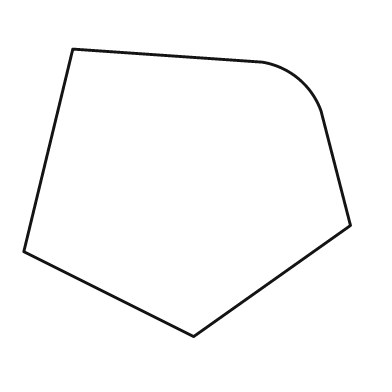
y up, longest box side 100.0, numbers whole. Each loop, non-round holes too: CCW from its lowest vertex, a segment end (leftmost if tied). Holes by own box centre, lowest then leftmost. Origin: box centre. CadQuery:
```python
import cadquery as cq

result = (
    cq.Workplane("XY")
    .moveTo(2.0, -44.0)
    .lineTo(50.0, -10.0)
    .lineTo(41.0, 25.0)
    .threePointArc((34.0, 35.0), (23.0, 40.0))
    .lineTo(-35.0, 44.0)
    .lineTo(-50.0, -18.0)
    .close()
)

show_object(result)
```